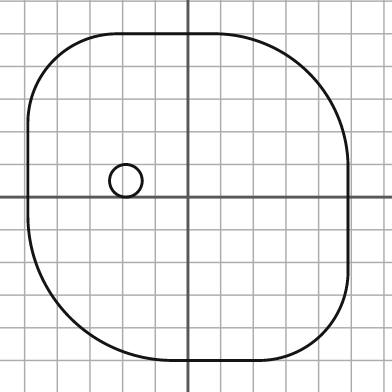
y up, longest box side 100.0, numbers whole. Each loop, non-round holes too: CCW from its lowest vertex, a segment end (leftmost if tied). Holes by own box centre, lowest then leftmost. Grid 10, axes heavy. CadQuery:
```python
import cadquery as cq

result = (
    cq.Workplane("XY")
    .moveTo(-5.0, -50.0)
    .lineTo(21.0, -50.0)
    .threePointArc((41.0, -42.0), (49.0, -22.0))
    .lineTo(49.0, 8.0)
    .threePointArc((37.0, 38.0), (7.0, 50.0))
    .lineTo(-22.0, 50.0)
    .threePointArc((-41.0, 42.0), (-49.0, 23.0))
    .lineTo(-49.0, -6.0)
    .threePointArc((-36.0, -37.0), (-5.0, -50.0))
    .close()
    .moveTo(-19.0, 5.0)
    .circle(5.0)
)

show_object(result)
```